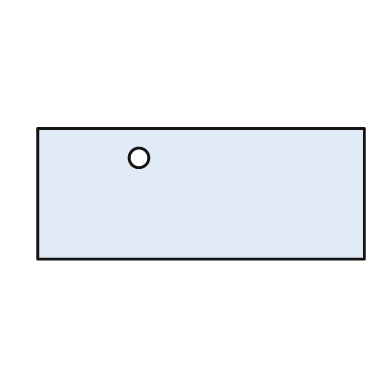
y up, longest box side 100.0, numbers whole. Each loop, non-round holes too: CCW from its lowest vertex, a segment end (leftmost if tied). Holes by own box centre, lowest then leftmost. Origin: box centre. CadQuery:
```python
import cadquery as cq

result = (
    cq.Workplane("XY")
    .moveTo(-50.0, -20.0)
    .lineTo(50.0, -20.0)
    .lineTo(50.0, 20.0)
    .lineTo(-50.0, 20.0)
    .close()
    .moveTo(-19.0, 11.0)
    .circle(3.0)
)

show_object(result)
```